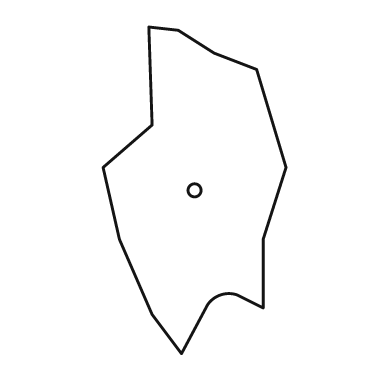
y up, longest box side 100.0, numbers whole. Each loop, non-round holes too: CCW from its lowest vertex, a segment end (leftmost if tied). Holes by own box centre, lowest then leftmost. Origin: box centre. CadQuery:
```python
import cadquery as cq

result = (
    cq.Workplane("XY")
    .moveTo(-4.0, -50.0)
    .lineTo(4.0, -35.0)
    .threePointArc((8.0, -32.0), (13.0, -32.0))
    .lineTo(21.0, -36.0)
    .lineTo(21.0, -15.0)
    .lineTo(28.0, 7.0)
    .lineTo(19.0, 37.0)
    .lineTo(6.0, 42.0)
    .lineTo(-5.0, 49.0)
    .lineTo(-14.0, 50.0)
    .lineTo(-13.0, 20.0)
    .lineTo(-28.0, 7.0)
    .lineTo(-23.0, -15.0)
    .lineTo(-13.0, -38.0)
    .close()
    .moveTo(0.0, 0.0)
    .circle(2.0)
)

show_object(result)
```